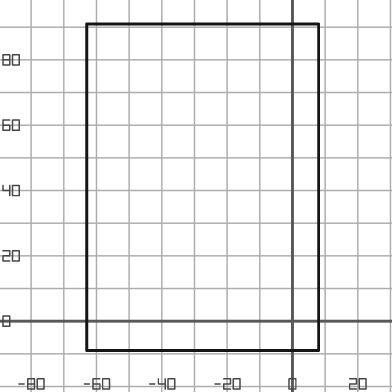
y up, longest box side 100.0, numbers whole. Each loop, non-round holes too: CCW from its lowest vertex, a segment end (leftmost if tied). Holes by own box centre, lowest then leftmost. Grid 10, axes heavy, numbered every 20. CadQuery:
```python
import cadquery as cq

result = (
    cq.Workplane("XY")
    .moveTo(-63.0, -9.0)
    .lineTo(8.0, -9.0)
    .lineTo(8.0, 91.0)
    .lineTo(-63.0, 91.0)
    .close()
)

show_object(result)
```